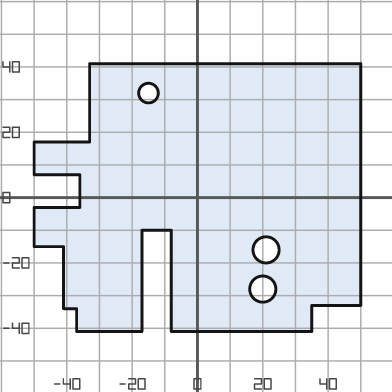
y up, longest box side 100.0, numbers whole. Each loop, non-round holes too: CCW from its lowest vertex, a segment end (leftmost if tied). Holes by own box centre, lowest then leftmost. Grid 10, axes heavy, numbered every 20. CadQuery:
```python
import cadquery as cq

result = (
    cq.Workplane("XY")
    .moveTo(-37.0, -41.0)
    .lineTo(-17.0, -41.0)
    .lineTo(-17.0, -10.0)
    .lineTo(-8.0, -10.0)
    .lineTo(-8.0, -41.0)
    .lineTo(35.0, -41.0)
    .lineTo(35.0, -33.0)
    .lineTo(50.0, -33.0)
    .lineTo(50.0, 41.0)
    .lineTo(-33.0, 41.0)
    .lineTo(-33.0, 17.0)
    .lineTo(-50.0, 17.0)
    .lineTo(-50.0, 7.0)
    .lineTo(-36.0, 7.0)
    .lineTo(-36.0, -3.0)
    .lineTo(-50.0, -3.0)
    .lineTo(-50.0, -15.0)
    .lineTo(-41.0, -15.0)
    .lineTo(-41.0, -34.0)
    .lineTo(-37.0, -34.0)
    .close()
    .moveTo(20.0, -28.0)
    .circle(4.0)
    .moveTo(21.0, -16.0)
    .circle(4.0)
    .moveTo(-15.0, 32.0)
    .circle(3.0)
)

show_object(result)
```